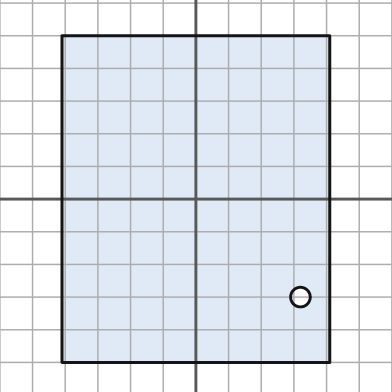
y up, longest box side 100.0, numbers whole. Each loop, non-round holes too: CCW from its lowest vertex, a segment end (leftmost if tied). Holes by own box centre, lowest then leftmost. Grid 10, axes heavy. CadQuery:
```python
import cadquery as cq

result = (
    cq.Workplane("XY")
    .moveTo(-41.0, -50.0)
    .lineTo(41.0, -50.0)
    .lineTo(41.0, 50.0)
    .lineTo(-41.0, 50.0)
    .close()
    .moveTo(32.0, -30.0)
    .circle(3.0)
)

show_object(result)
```